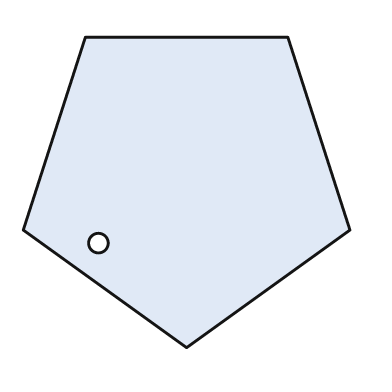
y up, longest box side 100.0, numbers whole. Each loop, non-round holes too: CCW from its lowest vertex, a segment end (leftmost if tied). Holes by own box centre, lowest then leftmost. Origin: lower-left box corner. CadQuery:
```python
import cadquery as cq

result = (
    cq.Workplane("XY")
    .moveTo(50.0, 0.0)
    .lineTo(100.0, 36.0)
    .lineTo(81.0, 95.0)
    .lineTo(19.0, 95.0)
    .lineTo(0.0, 36.0)
    .close()
    .moveTo(23.0, 32.0)
    .circle(3.0)
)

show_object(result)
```